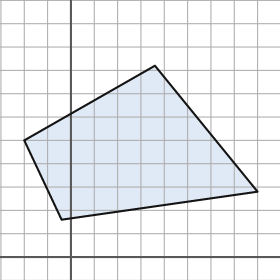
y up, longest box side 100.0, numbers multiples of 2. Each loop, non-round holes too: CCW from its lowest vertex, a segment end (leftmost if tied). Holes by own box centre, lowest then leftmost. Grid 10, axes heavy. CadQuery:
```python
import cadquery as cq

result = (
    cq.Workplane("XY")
    .moveTo(-4.0, 16.0)
    .lineTo(80.0, 28.0)
    .lineTo(36.0, 82.0)
    .lineTo(-20.0, 50.0)
    .close()
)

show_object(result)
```